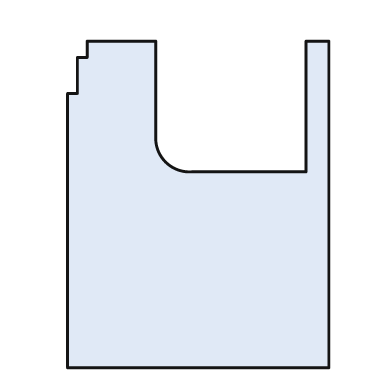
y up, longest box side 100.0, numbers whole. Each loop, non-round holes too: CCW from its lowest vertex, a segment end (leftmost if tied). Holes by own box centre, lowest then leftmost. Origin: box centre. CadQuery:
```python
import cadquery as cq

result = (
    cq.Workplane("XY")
    .moveTo(-40.0, -50.0)
    .lineTo(40.0, -50.0)
    .lineTo(40.0, 50.0)
    .lineTo(33.0, 50.0)
    .lineTo(33.0, 10.0)
    .lineTo(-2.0, 10.0)
    .threePointArc((-10.0, 13.0), (-13.0, 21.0))
    .lineTo(-13.0, 50.0)
    .lineTo(-34.0, 50.0)
    .lineTo(-34.0, 45.0)
    .lineTo(-37.0, 45.0)
    .lineTo(-37.0, 34.0)
    .lineTo(-40.0, 34.0)
    .close()
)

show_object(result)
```